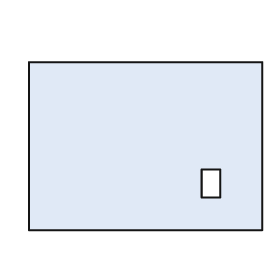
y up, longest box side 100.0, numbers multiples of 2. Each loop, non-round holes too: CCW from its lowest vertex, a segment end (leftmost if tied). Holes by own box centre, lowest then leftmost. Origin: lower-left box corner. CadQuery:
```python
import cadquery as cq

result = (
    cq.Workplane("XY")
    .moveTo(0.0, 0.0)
    .lineTo(100.0, 0.0)
    .lineTo(100.0, 72.0)
    .lineTo(0.0, 72.0)
    .close()
    .moveTo(74.0, 14.0)
    .lineTo(82.0, 14.0)
    .lineTo(82.0, 26.0)
    .lineTo(74.0, 26.0)
    .close()
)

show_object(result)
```